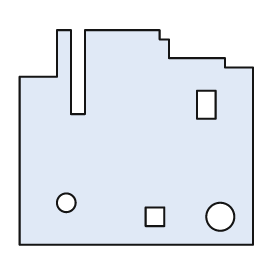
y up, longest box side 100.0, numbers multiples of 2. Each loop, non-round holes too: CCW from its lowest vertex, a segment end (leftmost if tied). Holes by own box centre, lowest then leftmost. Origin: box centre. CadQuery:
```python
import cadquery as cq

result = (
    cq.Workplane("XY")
    .moveTo(-50.0, -46.0)
    .lineTo(50.0, -46.0)
    .lineTo(50.0, 30.0)
    .lineTo(38.0, 30.0)
    .lineTo(38.0, 34.0)
    .lineTo(14.0, 34.0)
    .lineTo(14.0, 42.0)
    .lineTo(10.0, 42.0)
    .lineTo(10.0, 46.0)
    .lineTo(-22.0, 46.0)
    .lineTo(-22.0, 10.0)
    .lineTo(-28.0, 10.0)
    .lineTo(-28.0, 46.0)
    .lineTo(-34.0, 46.0)
    .lineTo(-34.0, 26.0)
    .lineTo(-50.0, 26.0)
    .close()
    .moveTo(4.0, -38.0)
    .lineTo(12.0, -38.0)
    .lineTo(12.0, -30.0)
    .lineTo(4.0, -30.0)
    .close()
    .moveTo(36.0, -34.0)
    .circle(6.0)
    .moveTo(-30.0, -28.0)
    .circle(4.0)
    .moveTo(26.0, 8.0)
    .lineTo(34.0, 8.0)
    .lineTo(34.0, 20.0)
    .lineTo(26.0, 20.0)
    .close()
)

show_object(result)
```